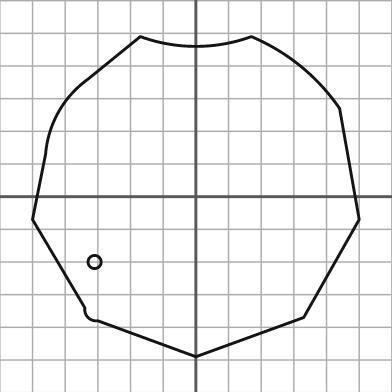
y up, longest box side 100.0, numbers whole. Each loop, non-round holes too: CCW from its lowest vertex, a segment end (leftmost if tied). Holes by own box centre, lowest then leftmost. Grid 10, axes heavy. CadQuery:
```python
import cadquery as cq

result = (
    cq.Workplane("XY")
    .moveTo(0.0, -49.0)
    .lineTo(33.0, -37.0)
    .lineTo(50.0, -7.0)
    .lineTo(44.0, 27.0)
    .threePointArc((32.0, 40.0), (17.0, 49.0))
    .threePointArc((0.0, 46.0), (-17.0, 49.0))
    .lineTo(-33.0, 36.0)
    .threePointArc((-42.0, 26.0), (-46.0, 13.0))
    .lineTo(-50.0, -7.0)
    .lineTo(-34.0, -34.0)
    .threePointArc((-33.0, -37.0), (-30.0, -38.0))
    .close()
    .moveTo(-31.0, -20.0)
    .circle(2.0)
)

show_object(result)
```